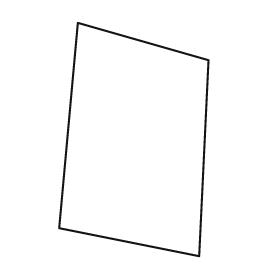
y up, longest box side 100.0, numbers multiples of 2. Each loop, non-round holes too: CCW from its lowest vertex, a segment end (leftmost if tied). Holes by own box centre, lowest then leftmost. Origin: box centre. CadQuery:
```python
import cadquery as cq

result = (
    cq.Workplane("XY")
    .moveTo(28.0, -50.0)
    .lineTo(32.0, 34.0)
    .lineTo(-24.0, 50.0)
    .lineTo(-32.0, -38.0)
    .close()
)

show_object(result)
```